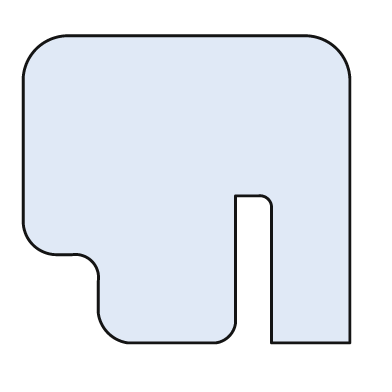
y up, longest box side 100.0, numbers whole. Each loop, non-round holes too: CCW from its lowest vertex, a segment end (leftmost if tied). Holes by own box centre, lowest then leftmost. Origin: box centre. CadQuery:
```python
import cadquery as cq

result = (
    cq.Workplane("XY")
    .moveTo(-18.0, -47.0)
    .lineTo(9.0, -47.0)
    .threePointArc((13.0, -45.0), (15.0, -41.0))
    .lineTo(15.0, -2.0)
    .lineTo(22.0, -2.0)
    .threePointArc((25.0, -3.0), (26.0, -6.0))
    .lineTo(26.0, -47.0)
    .lineTo(50.0, -47.0)
    .lineTo(50.0, 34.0)
    .threePointArc((46.0, 43.0), (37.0, 47.0))
    .lineTo(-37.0, 47.0)
    .threePointArc((-46.0, 43.0), (-50.0, 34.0))
    .lineTo(-50.0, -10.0)
    .threePointArc((-47.0, -17.0), (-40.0, -20.0))
    .lineTo(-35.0, -20.0)
    .threePointArc((-29.0, -22.0), (-27.0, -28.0))
    .lineTo(-27.0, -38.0)
    .threePointArc((-24.0, -44.0), (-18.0, -47.0))
    .close()
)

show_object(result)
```